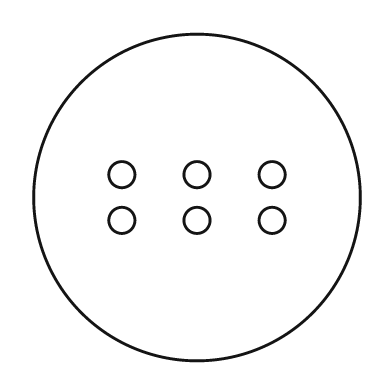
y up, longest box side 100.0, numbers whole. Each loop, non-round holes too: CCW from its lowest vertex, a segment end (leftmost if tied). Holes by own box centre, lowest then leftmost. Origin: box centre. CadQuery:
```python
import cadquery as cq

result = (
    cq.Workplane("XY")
    .moveTo(0.0, 0.0)
    .circle(50.0)
    .moveTo(-23.0, -7.0)
    .circle(4.0)
    .moveTo(0.0, -7.0)
    .circle(4.0)
    .moveTo(23.0, -7.0)
    .circle(4.0)
    .moveTo(-23.0, 7.0)
    .circle(4.0)
    .moveTo(0.0, 7.0)
    .circle(4.0)
    .moveTo(23.0, 7.0)
    .circle(4.0)
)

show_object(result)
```